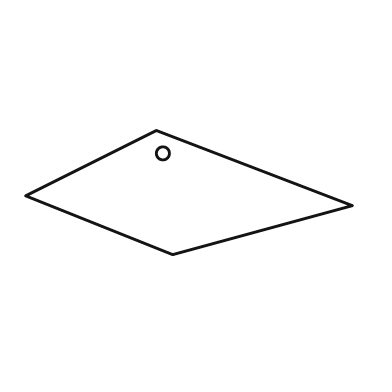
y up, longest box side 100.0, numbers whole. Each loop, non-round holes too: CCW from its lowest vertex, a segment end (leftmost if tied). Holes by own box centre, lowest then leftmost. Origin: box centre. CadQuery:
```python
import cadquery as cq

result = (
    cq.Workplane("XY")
    .moveTo(-5.0, -19.0)
    .lineTo(50.0, -4.0)
    .lineTo(-10.0, 19.0)
    .lineTo(-50.0, -1.0)
    .close()
    .moveTo(-8.0, 12.0)
    .circle(2.0)
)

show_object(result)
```